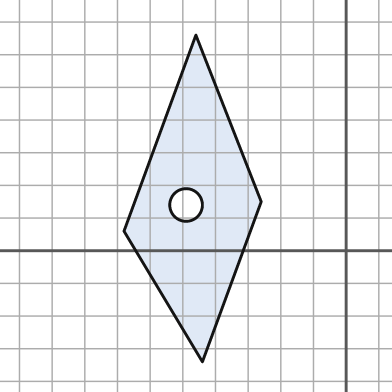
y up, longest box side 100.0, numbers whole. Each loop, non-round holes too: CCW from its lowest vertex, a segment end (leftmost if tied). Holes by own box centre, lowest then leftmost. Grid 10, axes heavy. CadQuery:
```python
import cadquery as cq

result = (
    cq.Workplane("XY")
    .moveTo(-44.0, -34.0)
    .lineTo(-26.0, 15.0)
    .lineTo(-46.0, 66.0)
    .lineTo(-68.0, 6.0)
    .close()
    .moveTo(-49.0, 14.0)
    .circle(5.0)
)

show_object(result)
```